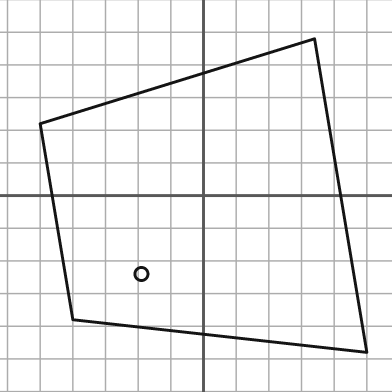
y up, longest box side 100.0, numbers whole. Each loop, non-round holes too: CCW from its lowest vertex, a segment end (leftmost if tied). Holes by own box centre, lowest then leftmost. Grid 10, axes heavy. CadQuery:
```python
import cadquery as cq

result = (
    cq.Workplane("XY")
    .moveTo(50.0, -48.0)
    .lineTo(34.0, 48.0)
    .lineTo(-50.0, 22.0)
    .lineTo(-40.0, -38.0)
    .close()
    .moveTo(-19.0, -24.0)
    .circle(2.0)
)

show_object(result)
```